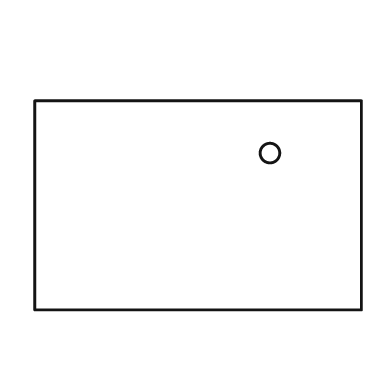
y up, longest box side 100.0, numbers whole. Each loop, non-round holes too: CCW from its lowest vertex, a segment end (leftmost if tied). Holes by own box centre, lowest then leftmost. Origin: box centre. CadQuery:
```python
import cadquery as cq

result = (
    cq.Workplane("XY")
    .moveTo(-50.0, -32.0)
    .lineTo(50.0, -32.0)
    .lineTo(50.0, 32.0)
    .lineTo(-50.0, 32.0)
    .close()
    .moveTo(22.0, 16.0)
    .circle(3.0)
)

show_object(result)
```